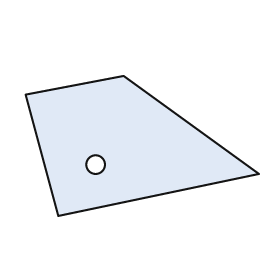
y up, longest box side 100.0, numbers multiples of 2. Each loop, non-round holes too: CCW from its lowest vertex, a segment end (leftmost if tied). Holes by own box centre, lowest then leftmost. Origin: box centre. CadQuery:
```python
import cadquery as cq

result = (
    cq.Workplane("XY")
    .moveTo(-36.0, -30.0)
    .lineTo(50.0, -12.0)
    .lineTo(-8.0, 30.0)
    .lineTo(-50.0, 22.0)
    .close()
    .moveTo(-20.0, -8.0)
    .circle(4.0)
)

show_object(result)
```